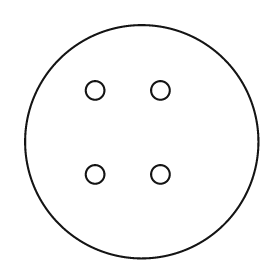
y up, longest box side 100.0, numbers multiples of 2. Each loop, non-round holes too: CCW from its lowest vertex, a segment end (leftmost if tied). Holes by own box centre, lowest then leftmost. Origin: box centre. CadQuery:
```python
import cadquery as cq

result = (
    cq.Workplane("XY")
    .moveTo(0.0, 0.0)
    .circle(50.0)
    .moveTo(-20.0, -14.0)
    .circle(4.0)
    .moveTo(8.0, -14.0)
    .circle(4.0)
    .moveTo(-20.0, 22.0)
    .circle(4.0)
    .moveTo(8.0, 22.0)
    .circle(4.0)
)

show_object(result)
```